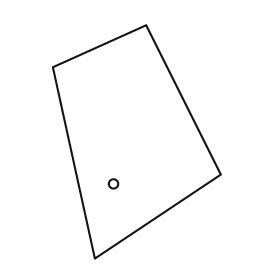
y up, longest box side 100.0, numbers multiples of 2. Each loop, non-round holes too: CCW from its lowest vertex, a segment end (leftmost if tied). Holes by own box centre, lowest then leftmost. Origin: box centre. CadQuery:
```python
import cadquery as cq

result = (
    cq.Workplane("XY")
    .moveTo(-18.0, -50.0)
    .lineTo(36.0, -14.0)
    .lineTo(4.0, 50.0)
    .lineTo(-36.0, 32.0)
    .close()
    .moveTo(-10.0, -18.0)
    .circle(2.0)
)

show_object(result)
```